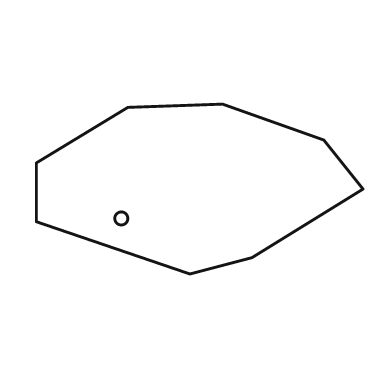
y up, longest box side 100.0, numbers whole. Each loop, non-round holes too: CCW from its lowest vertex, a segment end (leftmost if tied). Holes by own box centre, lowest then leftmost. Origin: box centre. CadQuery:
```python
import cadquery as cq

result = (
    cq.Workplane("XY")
    .moveTo(-3.0, -26.0)
    .lineTo(16.0, -21.0)
    .lineTo(50.0, 0.0)
    .lineTo(38.0, 15.0)
    .lineTo(7.0, 26.0)
    .lineTo(-22.0, 25.0)
    .lineTo(-50.0, 8.0)
    .lineTo(-50.0, -10.0)
    .close()
    .moveTo(-24.0, -9.0)
    .circle(2.0)
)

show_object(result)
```